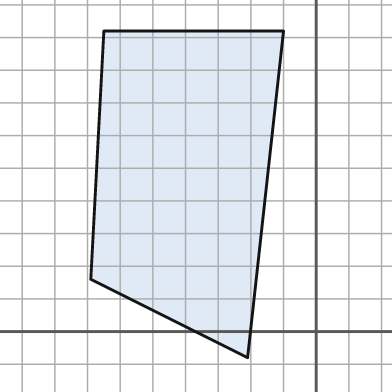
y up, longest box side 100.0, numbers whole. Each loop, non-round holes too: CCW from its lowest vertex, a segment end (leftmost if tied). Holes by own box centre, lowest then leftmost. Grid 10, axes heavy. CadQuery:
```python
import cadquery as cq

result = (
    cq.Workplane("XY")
    .moveTo(-21.0, -8.0)
    .lineTo(-10.0, 92.0)
    .lineTo(-65.0, 92.0)
    .lineTo(-69.0, 16.0)
    .close()
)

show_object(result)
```